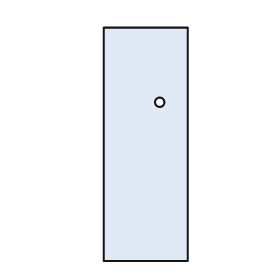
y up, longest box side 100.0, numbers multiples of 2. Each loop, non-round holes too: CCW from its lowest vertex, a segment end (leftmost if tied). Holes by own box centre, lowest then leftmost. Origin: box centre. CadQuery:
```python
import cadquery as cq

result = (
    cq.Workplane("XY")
    .moveTo(-18.0, -50.0)
    .lineTo(18.0, -50.0)
    .lineTo(18.0, 50.0)
    .lineTo(-18.0, 50.0)
    .close()
    .moveTo(6.0, 18.0)
    .circle(2.0)
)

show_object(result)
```